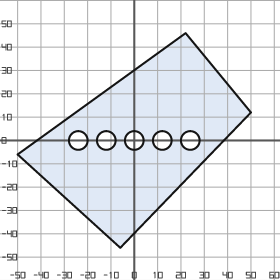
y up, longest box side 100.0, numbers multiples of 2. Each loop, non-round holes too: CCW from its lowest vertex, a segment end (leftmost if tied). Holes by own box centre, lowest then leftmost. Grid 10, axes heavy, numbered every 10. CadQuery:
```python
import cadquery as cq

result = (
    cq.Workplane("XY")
    .moveTo(-6.0, -46.0)
    .lineTo(50.0, 12.0)
    .lineTo(22.0, 46.0)
    .lineTo(-50.0, -6.0)
    .close()
    .moveTo(-24.0, 0.0)
    .circle(4.0)
    .moveTo(-12.0, 0.0)
    .circle(4.0)
    .moveTo(0.0, 0.0)
    .circle(4.0)
    .moveTo(12.0, 0.0)
    .circle(4.0)
    .moveTo(24.0, 0.0)
    .circle(4.0)
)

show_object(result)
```